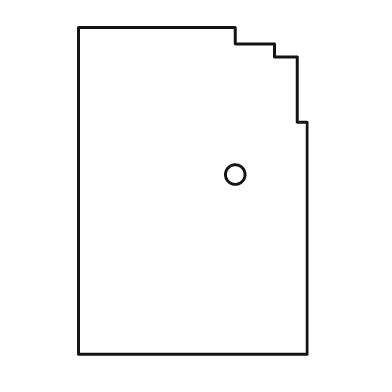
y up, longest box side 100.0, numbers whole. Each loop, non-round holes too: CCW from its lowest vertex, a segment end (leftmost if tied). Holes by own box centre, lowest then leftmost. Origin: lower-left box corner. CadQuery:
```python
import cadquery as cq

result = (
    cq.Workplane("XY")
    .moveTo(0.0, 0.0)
    .lineTo(70.0, 0.0)
    .lineTo(70.0, 71.0)
    .lineTo(67.0, 71.0)
    .lineTo(67.0, 91.0)
    .lineTo(60.0, 91.0)
    .lineTo(60.0, 95.0)
    .lineTo(48.0, 95.0)
    .lineTo(48.0, 100.0)
    .lineTo(0.0, 100.0)
    .close()
    .moveTo(48.0, 55.0)
    .circle(3.0)
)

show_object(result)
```